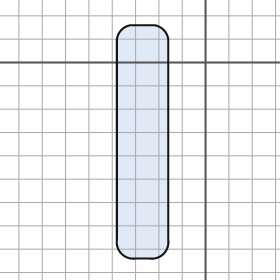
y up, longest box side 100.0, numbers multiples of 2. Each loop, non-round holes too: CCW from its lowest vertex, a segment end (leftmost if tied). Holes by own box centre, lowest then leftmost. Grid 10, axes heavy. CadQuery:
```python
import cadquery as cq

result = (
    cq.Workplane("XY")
    .moveTo(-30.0, -84.0)
    .lineTo(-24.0, -84.0)
    .threePointArc((-18.0, -82.0), (-16.0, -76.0))
    .lineTo(-16.0, 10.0)
    .threePointArc((-18.0, 14.0), (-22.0, 16.0))
    .lineTo(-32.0, 16.0)
    .threePointArc((-36.0, 14.0), (-38.0, 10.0))
    .lineTo(-38.0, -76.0)
    .threePointArc((-36.0, -82.0), (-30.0, -84.0))
    .close()
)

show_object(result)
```